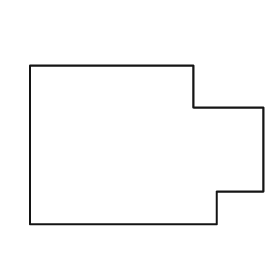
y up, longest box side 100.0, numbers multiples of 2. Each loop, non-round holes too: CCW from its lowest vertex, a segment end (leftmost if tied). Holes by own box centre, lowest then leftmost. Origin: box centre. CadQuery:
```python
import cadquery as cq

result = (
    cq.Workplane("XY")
    .moveTo(-50.0, -34.0)
    .lineTo(30.0, -34.0)
    .lineTo(30.0, -20.0)
    .lineTo(50.0, -20.0)
    .lineTo(50.0, 16.0)
    .lineTo(20.0, 16.0)
    .lineTo(20.0, 34.0)
    .lineTo(-50.0, 34.0)
    .close()
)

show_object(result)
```